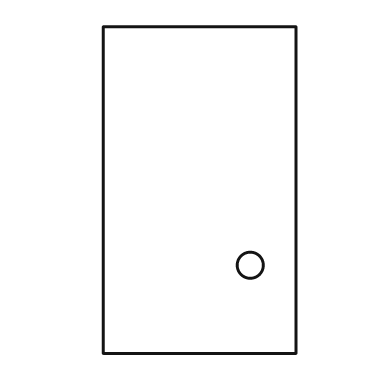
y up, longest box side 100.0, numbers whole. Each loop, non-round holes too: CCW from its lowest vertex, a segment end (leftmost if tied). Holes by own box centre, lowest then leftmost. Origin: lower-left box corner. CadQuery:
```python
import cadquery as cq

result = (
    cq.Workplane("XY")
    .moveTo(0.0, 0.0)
    .lineTo(59.0, 0.0)
    .lineTo(59.0, 100.0)
    .lineTo(0.0, 100.0)
    .close()
    .moveTo(45.0, 27.0)
    .circle(4.0)
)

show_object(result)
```